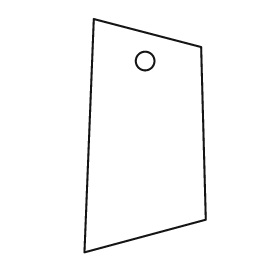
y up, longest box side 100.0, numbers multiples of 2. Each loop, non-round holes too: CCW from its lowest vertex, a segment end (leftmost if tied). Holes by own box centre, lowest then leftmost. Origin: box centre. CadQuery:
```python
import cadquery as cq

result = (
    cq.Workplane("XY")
    .moveTo(-26.0, -50.0)
    .lineTo(26.0, -36.0)
    .lineTo(24.0, 38.0)
    .lineTo(-22.0, 50.0)
    .close()
    .moveTo(0.0, 32.0)
    .circle(4.0)
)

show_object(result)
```